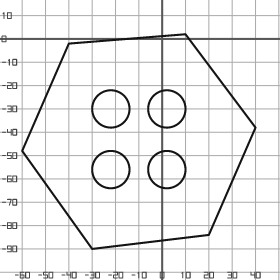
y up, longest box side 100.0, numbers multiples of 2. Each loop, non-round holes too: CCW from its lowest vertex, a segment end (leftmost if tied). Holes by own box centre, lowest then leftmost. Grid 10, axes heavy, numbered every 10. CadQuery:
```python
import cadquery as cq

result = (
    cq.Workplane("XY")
    .moveTo(-30.0, -90.0)
    .lineTo(20.0, -84.0)
    .lineTo(40.0, -38.0)
    .lineTo(10.0, 2.0)
    .lineTo(-40.0, -2.0)
    .lineTo(-60.0, -48.0)
    .close()
    .moveTo(-22.0, -56.0)
    .circle(8.0)
    .moveTo(2.0, -56.0)
    .circle(8.0)
    .moveTo(-22.0, -30.0)
    .circle(8.0)
    .moveTo(2.0, -30.0)
    .circle(8.0)
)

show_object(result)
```